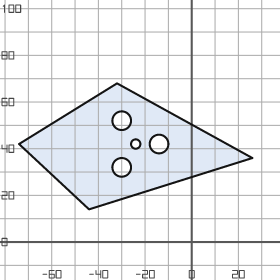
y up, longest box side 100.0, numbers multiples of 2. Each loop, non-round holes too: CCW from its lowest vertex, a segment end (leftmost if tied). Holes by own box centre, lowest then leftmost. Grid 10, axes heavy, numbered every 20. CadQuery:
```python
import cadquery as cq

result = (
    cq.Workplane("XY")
    .moveTo(-44.0, 14.0)
    .lineTo(26.0, 36.0)
    .lineTo(-32.0, 68.0)
    .lineTo(-74.0, 42.0)
    .close()
    .moveTo(-30.0, 32.0)
    .circle(4.0)
    .moveTo(-24.0, 42.0)
    .circle(2.0)
    .moveTo(-14.0, 42.0)
    .circle(4.0)
    .moveTo(-30.0, 52.0)
    .circle(4.0)
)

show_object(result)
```